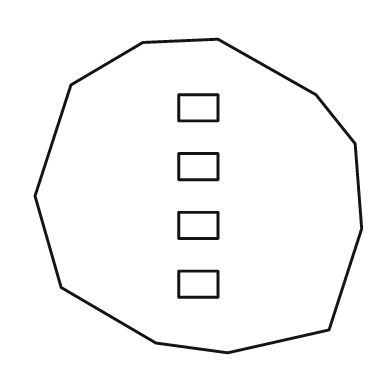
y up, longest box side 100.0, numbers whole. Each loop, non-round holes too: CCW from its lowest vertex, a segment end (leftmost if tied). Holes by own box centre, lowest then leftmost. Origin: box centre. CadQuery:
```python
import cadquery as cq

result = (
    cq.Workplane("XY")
    .moveTo(9.0, -48.0)
    .lineTo(40.0, -41.0)
    .lineTo(50.0, -10.0)
    .lineTo(48.0, 16.0)
    .lineTo(36.0, 31.0)
    .lineTo(6.0, 48.0)
    .lineTo(-17.0, 47.0)
    .lineTo(-39.0, 34.0)
    .lineTo(-50.0, 0.0)
    .lineTo(-42.0, -28.0)
    .lineTo(-13.0, -45.0)
    .close()
    .moveTo(-6.0, -31.0)
    .lineTo(6.0, -31.0)
    .lineTo(6.0, -23.0)
    .lineTo(-6.0, -23.0)
    .close()
    .moveTo(-6.0, -13.0)
    .lineTo(6.0, -13.0)
    .lineTo(6.0, -5.0)
    .lineTo(-6.0, -5.0)
    .close()
    .moveTo(-6.0, 5.0)
    .lineTo(6.0, 5.0)
    .lineTo(6.0, 13.0)
    .lineTo(-6.0, 13.0)
    .close()
    .moveTo(-6.0, 23.0)
    .lineTo(6.0, 23.0)
    .lineTo(6.0, 31.0)
    .lineTo(-6.0, 31.0)
    .close()
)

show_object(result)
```